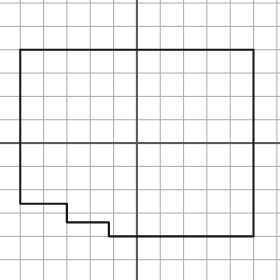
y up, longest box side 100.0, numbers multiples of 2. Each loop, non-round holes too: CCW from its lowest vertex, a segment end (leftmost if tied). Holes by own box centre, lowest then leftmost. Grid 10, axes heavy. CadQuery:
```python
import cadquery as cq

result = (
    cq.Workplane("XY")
    .moveTo(-12.0, -40.0)
    .lineTo(50.0, -40.0)
    .lineTo(50.0, 40.0)
    .lineTo(-50.0, 40.0)
    .lineTo(-50.0, -26.0)
    .lineTo(-30.0, -26.0)
    .lineTo(-30.0, -34.0)
    .lineTo(-12.0, -34.0)
    .close()
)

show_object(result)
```